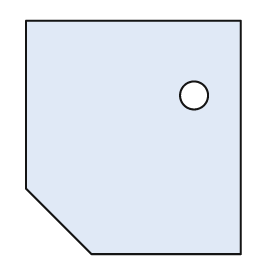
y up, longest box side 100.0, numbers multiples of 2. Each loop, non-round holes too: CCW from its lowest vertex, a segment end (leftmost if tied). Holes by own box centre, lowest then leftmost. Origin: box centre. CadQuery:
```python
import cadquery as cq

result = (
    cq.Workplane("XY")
    .moveTo(-18.0, -50.0)
    .lineTo(46.0, -50.0)
    .lineTo(46.0, 50.0)
    .lineTo(-46.0, 50.0)
    .lineTo(-46.0, -22.0)
    .close()
    .moveTo(26.0, 18.0)
    .circle(6.0)
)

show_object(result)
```